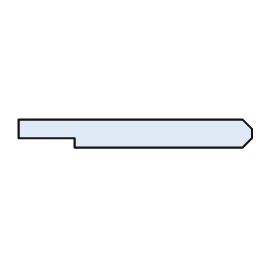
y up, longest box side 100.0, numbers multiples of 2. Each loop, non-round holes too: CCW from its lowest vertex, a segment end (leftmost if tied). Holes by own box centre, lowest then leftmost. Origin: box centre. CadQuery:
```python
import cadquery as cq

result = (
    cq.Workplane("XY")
    .moveTo(-26.0, -6.0)
    .lineTo(46.0, -6.0)
    .lineTo(50.0, -2.0)
    .lineTo(50.0, 2.0)
    .lineTo(46.0, 6.0)
    .lineTo(-50.0, 6.0)
    .lineTo(-50.0, -2.0)
    .lineTo(-26.0, -2.0)
    .close()
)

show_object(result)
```